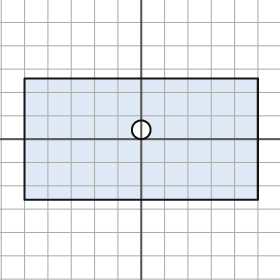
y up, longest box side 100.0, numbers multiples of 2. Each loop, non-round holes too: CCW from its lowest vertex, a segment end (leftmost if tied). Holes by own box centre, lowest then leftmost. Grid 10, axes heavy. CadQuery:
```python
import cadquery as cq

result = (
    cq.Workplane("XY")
    .moveTo(-50.0, -26.0)
    .lineTo(50.0, -26.0)
    .lineTo(50.0, 26.0)
    .lineTo(-50.0, 26.0)
    .close()
    .moveTo(0.0, 4.0)
    .circle(4.0)
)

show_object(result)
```